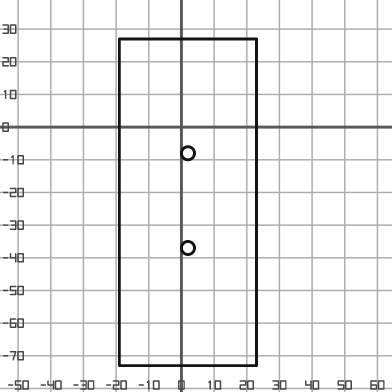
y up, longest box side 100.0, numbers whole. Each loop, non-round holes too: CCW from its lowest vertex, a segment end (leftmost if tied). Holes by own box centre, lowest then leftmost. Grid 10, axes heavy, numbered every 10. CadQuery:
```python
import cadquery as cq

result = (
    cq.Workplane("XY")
    .moveTo(-19.0, -73.0)
    .lineTo(23.0, -73.0)
    .lineTo(23.0, 27.0)
    .lineTo(-19.0, 27.0)
    .close()
    .moveTo(2.0, -37.0)
    .circle(2.0)
    .moveTo(2.0, -8.0)
    .circle(2.0)
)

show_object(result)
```